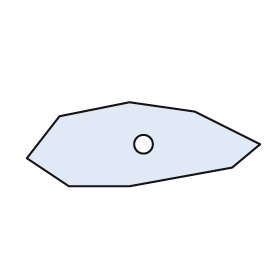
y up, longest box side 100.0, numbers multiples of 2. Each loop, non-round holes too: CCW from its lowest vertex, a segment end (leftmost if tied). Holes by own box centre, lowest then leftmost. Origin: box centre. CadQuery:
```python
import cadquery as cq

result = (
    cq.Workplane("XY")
    .moveTo(-32.0, -18.0)
    .lineTo(-6.0, -18.0)
    .lineTo(38.0, -10.0)
    .lineTo(50.0, 0.0)
    .lineTo(22.0, 14.0)
    .lineTo(-6.0, 18.0)
    .lineTo(-36.0, 12.0)
    .lineTo(-50.0, -6.0)
    .close()
    .moveTo(0.0, 0.0)
    .circle(4.0)
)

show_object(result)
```